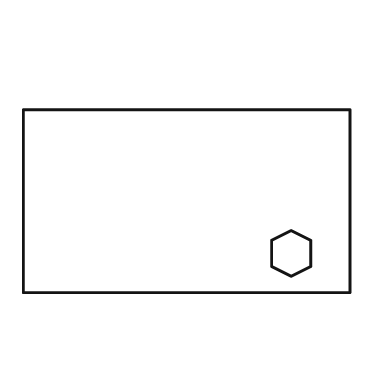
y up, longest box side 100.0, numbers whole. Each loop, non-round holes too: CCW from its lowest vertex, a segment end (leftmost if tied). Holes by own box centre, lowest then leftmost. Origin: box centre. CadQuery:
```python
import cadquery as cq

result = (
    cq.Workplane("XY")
    .moveTo(-50.0, -28.0)
    .lineTo(50.0, -28.0)
    .lineTo(50.0, 28.0)
    .lineTo(-50.0, 28.0)
    .close()
    .moveTo(32.0, -23.0)
    .lineTo(38.0, -20.0)
    .lineTo(38.0, -12.0)
    .lineTo(32.0, -9.0)
    .lineTo(26.0, -12.0)
    .lineTo(26.0, -20.0)
    .close()
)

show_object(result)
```